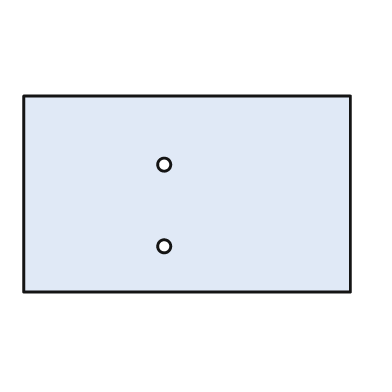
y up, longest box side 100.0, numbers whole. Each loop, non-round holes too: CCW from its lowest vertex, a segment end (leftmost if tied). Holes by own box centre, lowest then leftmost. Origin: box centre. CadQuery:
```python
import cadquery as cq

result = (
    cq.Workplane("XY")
    .moveTo(-50.0, -30.0)
    .lineTo(50.0, -30.0)
    .lineTo(50.0, 30.0)
    .lineTo(-50.0, 30.0)
    .close()
    .moveTo(-7.0, -16.0)
    .circle(2.0)
    .moveTo(-7.0, 9.0)
    .circle(2.0)
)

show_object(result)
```